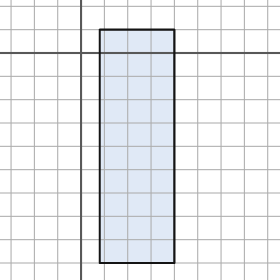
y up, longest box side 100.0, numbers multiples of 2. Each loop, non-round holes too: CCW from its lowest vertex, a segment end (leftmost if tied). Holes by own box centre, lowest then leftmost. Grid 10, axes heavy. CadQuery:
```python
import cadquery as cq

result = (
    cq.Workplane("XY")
    .moveTo(8.0, -90.0)
    .lineTo(40.0, -90.0)
    .lineTo(40.0, 10.0)
    .lineTo(8.0, 10.0)
    .close()
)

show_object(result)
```